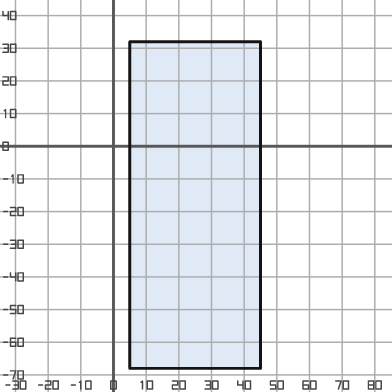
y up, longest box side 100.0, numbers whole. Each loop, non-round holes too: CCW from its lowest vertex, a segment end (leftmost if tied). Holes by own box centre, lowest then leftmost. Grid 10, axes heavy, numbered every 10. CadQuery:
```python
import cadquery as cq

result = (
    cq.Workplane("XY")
    .moveTo(5.0, -68.0)
    .lineTo(45.0, -68.0)
    .lineTo(45.0, 32.0)
    .lineTo(5.0, 32.0)
    .close()
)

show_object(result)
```